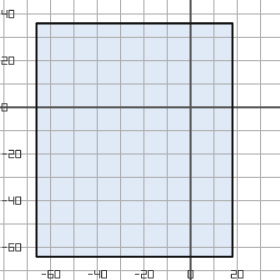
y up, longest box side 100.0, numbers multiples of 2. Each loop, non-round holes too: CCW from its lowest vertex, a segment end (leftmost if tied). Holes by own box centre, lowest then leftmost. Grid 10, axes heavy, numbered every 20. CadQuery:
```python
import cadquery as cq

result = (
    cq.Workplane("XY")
    .moveTo(-66.0, -64.0)
    .lineTo(18.0, -64.0)
    .lineTo(18.0, 36.0)
    .lineTo(-66.0, 36.0)
    .close()
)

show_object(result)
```